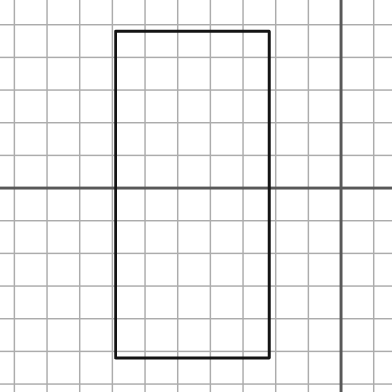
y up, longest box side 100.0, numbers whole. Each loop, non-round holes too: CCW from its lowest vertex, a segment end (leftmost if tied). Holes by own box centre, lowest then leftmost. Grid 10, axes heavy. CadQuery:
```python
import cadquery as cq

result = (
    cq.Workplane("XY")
    .moveTo(-69.0, -52.0)
    .lineTo(-22.0, -52.0)
    .lineTo(-22.0, 48.0)
    .lineTo(-69.0, 48.0)
    .close()
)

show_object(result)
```